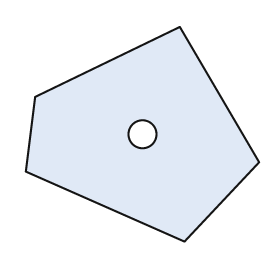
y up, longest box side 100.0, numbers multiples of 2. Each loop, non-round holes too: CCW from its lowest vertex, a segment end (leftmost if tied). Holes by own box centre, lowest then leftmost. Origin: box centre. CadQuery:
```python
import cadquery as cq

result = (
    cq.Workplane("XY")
    .moveTo(18.0, -46.0)
    .lineTo(50.0, -12.0)
    .lineTo(16.0, 46.0)
    .lineTo(-46.0, 16.0)
    .lineTo(-50.0, -16.0)
    .close()
    .moveTo(0.0, 0.0)
    .circle(6.0)
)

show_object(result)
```